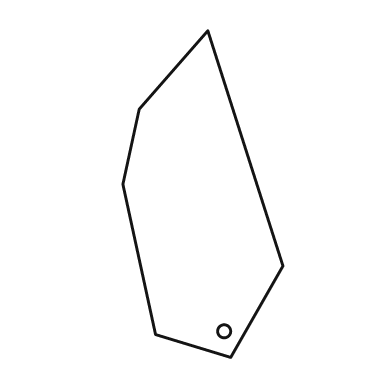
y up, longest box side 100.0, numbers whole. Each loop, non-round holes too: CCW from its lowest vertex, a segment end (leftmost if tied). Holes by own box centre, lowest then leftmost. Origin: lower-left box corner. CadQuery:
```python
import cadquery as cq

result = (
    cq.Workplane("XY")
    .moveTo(33.0, 0.0)
    .lineTo(49.0, 28.0)
    .lineTo(26.0, 100.0)
    .lineTo(5.0, 76.0)
    .lineTo(0.0, 53.0)
    .lineTo(10.0, 7.0)
    .close()
    .moveTo(31.0, 8.0)
    .circle(2.0)
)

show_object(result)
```